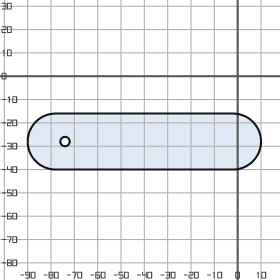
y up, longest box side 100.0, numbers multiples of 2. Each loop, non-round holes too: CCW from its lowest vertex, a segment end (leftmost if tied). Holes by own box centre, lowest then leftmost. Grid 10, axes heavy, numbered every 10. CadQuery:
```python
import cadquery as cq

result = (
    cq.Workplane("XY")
    .moveTo(-78.0, -40.0)
    .lineTo(-2.0, -40.0)
    .threePointArc((10.0, -28.0), (-2.0, -16.0))
    .lineTo(-78.0, -16.0)
    .threePointArc((-90.0, -28.0), (-78.0, -40.0))
    .close()
    .moveTo(-74.0, -28.0)
    .circle(2.0)
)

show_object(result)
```